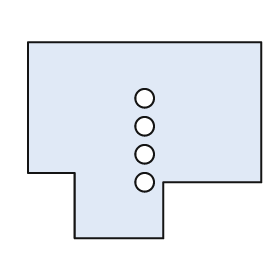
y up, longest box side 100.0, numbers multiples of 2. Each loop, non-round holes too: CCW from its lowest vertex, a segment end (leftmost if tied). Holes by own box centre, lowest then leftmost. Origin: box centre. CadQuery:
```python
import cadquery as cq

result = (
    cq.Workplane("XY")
    .moveTo(-30.0, -42.0)
    .lineTo(8.0, -42.0)
    .lineTo(8.0, -18.0)
    .lineTo(50.0, -18.0)
    .lineTo(50.0, 42.0)
    .lineTo(-50.0, 42.0)
    .lineTo(-50.0, -14.0)
    .lineTo(-30.0, -14.0)
    .close()
    .moveTo(0.0, -18.0)
    .circle(4.0)
    .moveTo(0.0, -6.0)
    .circle(4.0)
    .moveTo(0.0, 6.0)
    .circle(4.0)
    .moveTo(0.0, 18.0)
    .circle(4.0)
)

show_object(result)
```